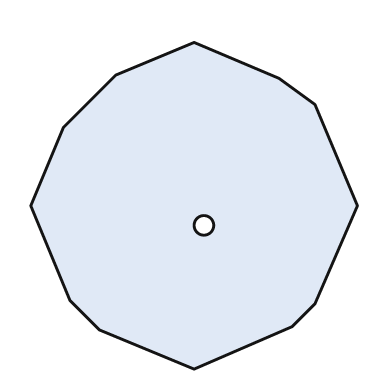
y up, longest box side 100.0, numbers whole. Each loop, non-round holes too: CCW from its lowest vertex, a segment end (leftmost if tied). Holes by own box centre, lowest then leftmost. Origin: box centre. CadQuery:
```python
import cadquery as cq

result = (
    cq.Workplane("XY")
    .moveTo(0.0, -50.0)
    .lineTo(30.0, -37.0)
    .lineTo(37.0, -30.0)
    .lineTo(50.0, 0.0)
    .lineTo(37.0, 31.0)
    .lineTo(26.0, 39.0)
    .lineTo(0.0, 50.0)
    .lineTo(-24.0, 40.0)
    .lineTo(-40.0, 24.0)
    .lineTo(-50.0, 0.0)
    .lineTo(-38.0, -29.0)
    .lineTo(-29.0, -38.0)
    .close()
    .moveTo(3.0, -6.0)
    .circle(3.0)
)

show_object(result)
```